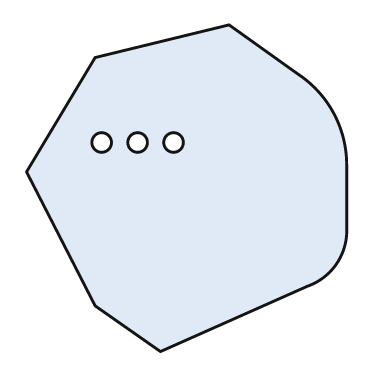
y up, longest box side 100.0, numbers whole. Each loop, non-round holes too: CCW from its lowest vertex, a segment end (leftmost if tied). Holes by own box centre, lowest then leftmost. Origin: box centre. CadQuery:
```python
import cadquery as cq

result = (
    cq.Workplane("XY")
    .moveTo(-8.0, -50.0)
    .lineTo(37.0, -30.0)
    .threePointArc((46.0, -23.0), (49.0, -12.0))
    .lineTo(49.0, 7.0)
    .threePointArc((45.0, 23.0), (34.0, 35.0))
    .lineTo(13.0, 50.0)
    .lineTo(-28.0, 40.0)
    .lineTo(-49.0, 5.0)
    .lineTo(-28.0, -36.0)
    .close()
    .moveTo(-26.0, 14.0)
    .circle(3.0)
    .moveTo(-15.0, 14.0)
    .circle(3.0)
    .moveTo(-4.0, 14.0)
    .circle(3.0)
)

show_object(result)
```